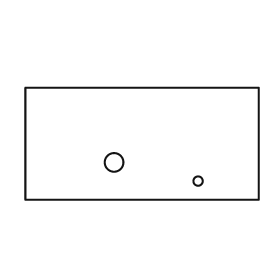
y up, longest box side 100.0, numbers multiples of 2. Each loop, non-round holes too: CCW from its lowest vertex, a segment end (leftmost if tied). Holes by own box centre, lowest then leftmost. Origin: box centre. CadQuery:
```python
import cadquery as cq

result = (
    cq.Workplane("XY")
    .moveTo(-50.0, -24.0)
    .lineTo(50.0, -24.0)
    .lineTo(50.0, 24.0)
    .lineTo(-50.0, 24.0)
    .close()
    .moveTo(24.0, -16.0)
    .circle(2.0)
    .moveTo(-12.0, -8.0)
    .circle(4.0)
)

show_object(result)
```